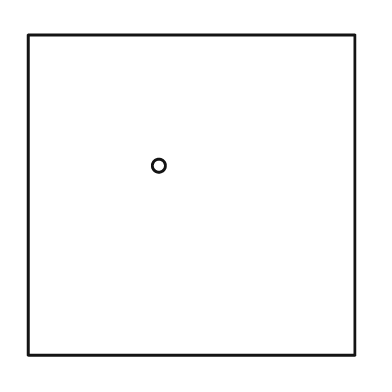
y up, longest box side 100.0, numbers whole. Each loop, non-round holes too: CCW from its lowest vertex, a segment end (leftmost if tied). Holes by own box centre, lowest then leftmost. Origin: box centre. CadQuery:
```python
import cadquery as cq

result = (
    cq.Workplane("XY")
    .moveTo(-50.0, -49.0)
    .lineTo(50.0, -49.0)
    .lineTo(50.0, 49.0)
    .lineTo(-50.0, 49.0)
    .close()
    .moveTo(-10.0, 9.0)
    .circle(2.0)
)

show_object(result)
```